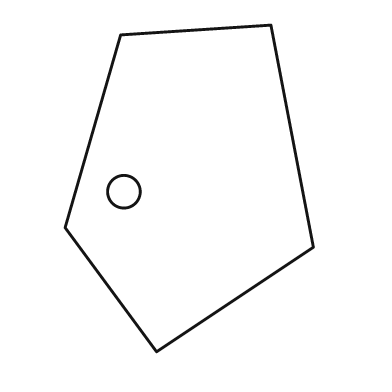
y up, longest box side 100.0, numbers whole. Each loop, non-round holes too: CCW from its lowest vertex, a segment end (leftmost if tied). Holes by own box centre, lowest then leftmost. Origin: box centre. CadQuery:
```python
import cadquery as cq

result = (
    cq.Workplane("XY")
    .moveTo(-10.0, -50.0)
    .lineTo(38.0, -18.0)
    .lineTo(25.0, 50.0)
    .lineTo(-21.0, 47.0)
    .lineTo(-38.0, -12.0)
    .close()
    .moveTo(-20.0, -1.0)
    .circle(5.0)
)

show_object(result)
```